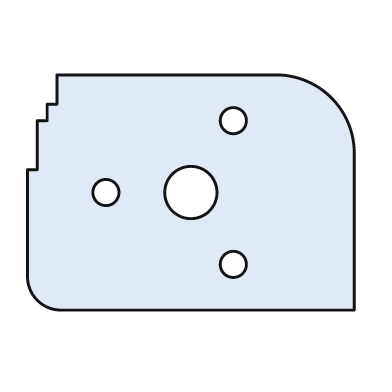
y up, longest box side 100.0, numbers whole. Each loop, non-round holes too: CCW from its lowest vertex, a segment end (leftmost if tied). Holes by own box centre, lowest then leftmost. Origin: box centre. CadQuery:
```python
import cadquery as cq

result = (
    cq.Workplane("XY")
    .moveTo(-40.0, -36.0)
    .lineTo(50.0, -36.0)
    .lineTo(50.0, 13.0)
    .threePointArc((43.0, 29.0), (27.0, 36.0))
    .lineTo(-41.0, 36.0)
    .lineTo(-41.0, 27.0)
    .lineTo(-44.0, 27.0)
    .lineTo(-44.0, 22.0)
    .lineTo(-47.0, 22.0)
    .lineTo(-47.0, 7.0)
    .lineTo(-50.0, 7.0)
    .lineTo(-50.0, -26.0)
    .threePointArc((-47.0, -33.0), (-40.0, -36.0))
    .close()
    .moveTo(13.0, -22.0)
    .circle(4.0)
    .moveTo(-26.0, 0.0)
    .circle(4.0)
    .moveTo(0.0, 0.0)
    .circle(8.0)
    .moveTo(13.0, 22.0)
    .circle(4.0)
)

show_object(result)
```